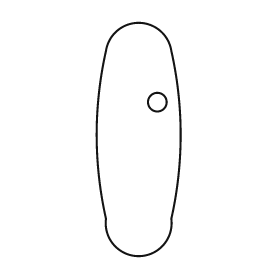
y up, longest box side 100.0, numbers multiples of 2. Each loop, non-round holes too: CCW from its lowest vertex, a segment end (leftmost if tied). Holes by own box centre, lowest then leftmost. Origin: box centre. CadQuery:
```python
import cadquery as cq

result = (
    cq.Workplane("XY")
    .moveTo(-14.0, -34.0)
    .threePointArc((0.0, -50.0), (14.0, -34.0))
    .threePointArc((18.0, 2.0), (14.0, 38.0))
    .threePointArc((0.0, 50.0), (-14.0, 38.0))
    .threePointArc((-18.0, 2.0), (-14.0, -34.0))
    .close()
    .moveTo(8.0, 16.0)
    .circle(4.0)
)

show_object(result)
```